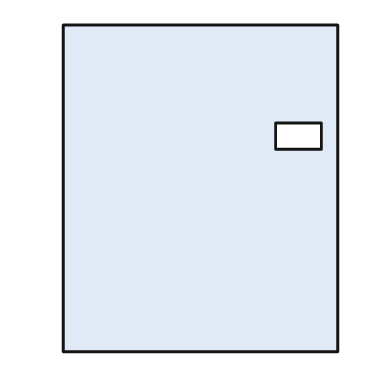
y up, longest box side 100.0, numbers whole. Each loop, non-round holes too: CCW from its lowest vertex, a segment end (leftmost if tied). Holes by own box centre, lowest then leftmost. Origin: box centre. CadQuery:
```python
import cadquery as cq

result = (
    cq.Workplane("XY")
    .moveTo(-42.0, -50.0)
    .lineTo(42.0, -50.0)
    .lineTo(42.0, 50.0)
    .lineTo(-42.0, 50.0)
    .close()
    .moveTo(23.0, 12.0)
    .lineTo(37.0, 12.0)
    .lineTo(37.0, 20.0)
    .lineTo(23.0, 20.0)
    .close()
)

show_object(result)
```